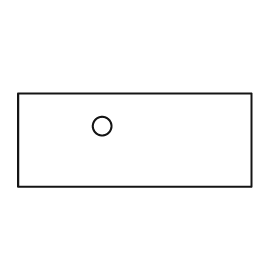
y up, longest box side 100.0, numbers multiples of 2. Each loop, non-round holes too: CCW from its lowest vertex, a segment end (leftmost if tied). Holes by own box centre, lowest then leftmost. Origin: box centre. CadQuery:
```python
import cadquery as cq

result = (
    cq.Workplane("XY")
    .moveTo(-50.0, -20.0)
    .lineTo(50.0, -20.0)
    .lineTo(50.0, 20.0)
    .lineTo(-50.0, 20.0)
    .close()
    .moveTo(-14.0, 6.0)
    .circle(4.0)
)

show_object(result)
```